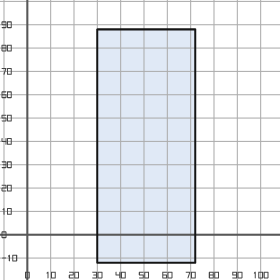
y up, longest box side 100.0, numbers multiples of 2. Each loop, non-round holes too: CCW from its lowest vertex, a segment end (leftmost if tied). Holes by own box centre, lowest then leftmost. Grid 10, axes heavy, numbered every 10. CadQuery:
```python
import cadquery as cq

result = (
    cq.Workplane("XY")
    .moveTo(30.0, -12.0)
    .lineTo(72.0, -12.0)
    .lineTo(72.0, 88.0)
    .lineTo(30.0, 88.0)
    .close()
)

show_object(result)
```